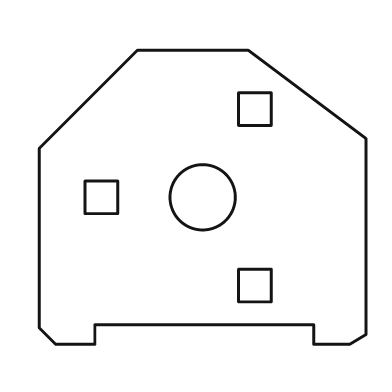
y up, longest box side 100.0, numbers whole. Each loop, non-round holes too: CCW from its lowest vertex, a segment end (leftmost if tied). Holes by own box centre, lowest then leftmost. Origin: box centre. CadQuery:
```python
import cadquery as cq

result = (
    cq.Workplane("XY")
    .moveTo(-45.0, -45.0)
    .lineTo(-33.0, -45.0)
    .lineTo(-33.0, -39.0)
    .lineTo(34.0, -39.0)
    .lineTo(34.0, -45.0)
    .lineTo(45.0, -45.0)
    .lineTo(50.0, -42.0)
    .lineTo(50.0, 18.0)
    .lineTo(14.0, 45.0)
    .lineTo(-20.0, 45.0)
    .lineTo(-50.0, 15.0)
    .lineTo(-50.0, -40.0)
    .close()
    .moveTo(11.0, -32.0)
    .lineTo(21.0, -32.0)
    .lineTo(21.0, -22.0)
    .lineTo(11.0, -22.0)
    .close()
    .moveTo(-36.0, -5.0)
    .lineTo(-26.0, -5.0)
    .lineTo(-26.0, 5.0)
    .lineTo(-36.0, 5.0)
    .close()
    .moveTo(0.0, 0.0)
    .circle(10.0)
    .moveTo(11.0, 22.0)
    .lineTo(21.0, 22.0)
    .lineTo(21.0, 32.0)
    .lineTo(11.0, 32.0)
    .close()
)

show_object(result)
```